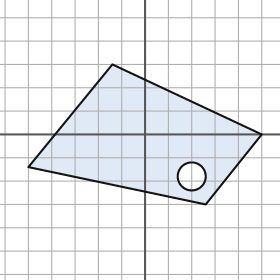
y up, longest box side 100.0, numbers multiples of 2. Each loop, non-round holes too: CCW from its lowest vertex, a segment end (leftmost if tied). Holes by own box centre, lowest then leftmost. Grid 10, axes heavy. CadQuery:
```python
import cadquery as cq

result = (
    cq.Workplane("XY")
    .moveTo(26.0, -30.0)
    .lineTo(50.0, 0.0)
    .lineTo(-14.0, 30.0)
    .lineTo(-50.0, -14.0)
    .close()
    .moveTo(20.0, -18.0)
    .circle(6.0)
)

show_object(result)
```